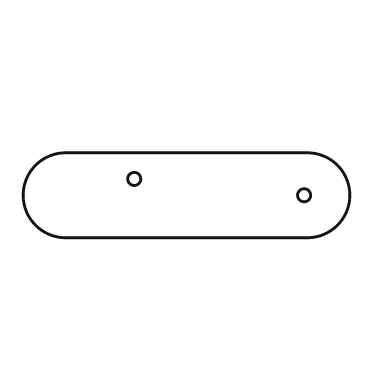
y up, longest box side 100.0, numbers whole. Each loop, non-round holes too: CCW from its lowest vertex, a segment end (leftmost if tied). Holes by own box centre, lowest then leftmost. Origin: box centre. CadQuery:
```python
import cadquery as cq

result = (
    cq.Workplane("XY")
    .moveTo(-37.0, -13.0)
    .lineTo(37.0, -13.0)
    .threePointArc((50.0, 0.0), (37.0, 13.0))
    .lineTo(-37.0, 13.0)
    .threePointArc((-50.0, 0.0), (-37.0, -13.0))
    .close()
    .moveTo(36.0, 0.0)
    .circle(2.0)
    .moveTo(-16.0, 5.0)
    .circle(2.0)
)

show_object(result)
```